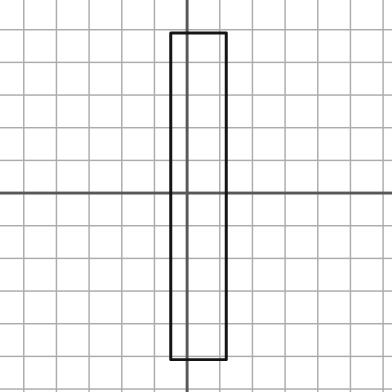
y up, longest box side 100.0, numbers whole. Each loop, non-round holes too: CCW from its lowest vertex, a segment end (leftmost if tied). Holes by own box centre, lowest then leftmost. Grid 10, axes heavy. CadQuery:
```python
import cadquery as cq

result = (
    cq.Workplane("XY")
    .moveTo(-5.0, -51.0)
    .lineTo(12.0, -51.0)
    .lineTo(12.0, 49.0)
    .lineTo(-5.0, 49.0)
    .close()
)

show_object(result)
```